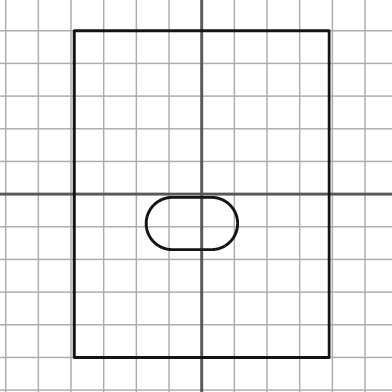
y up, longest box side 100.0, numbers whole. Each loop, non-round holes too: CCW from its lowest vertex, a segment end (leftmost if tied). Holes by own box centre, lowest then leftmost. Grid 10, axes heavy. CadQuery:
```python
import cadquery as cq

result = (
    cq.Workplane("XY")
    .moveTo(-39.0, -50.0)
    .lineTo(39.0, -50.0)
    .lineTo(39.0, 50.0)
    .lineTo(-39.0, 50.0)
    .close()
    .moveTo(-9.0, -17.0)
    .lineTo(3.0, -17.0)
    .threePointArc((11.0, -9.0), (3.0, -1.0))
    .lineTo(-9.0, -1.0)
    .threePointArc((-17.0, -9.0), (-9.0, -17.0))
    .close()
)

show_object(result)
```